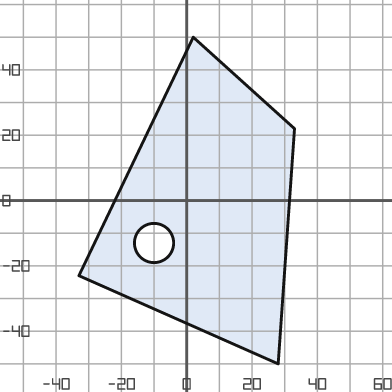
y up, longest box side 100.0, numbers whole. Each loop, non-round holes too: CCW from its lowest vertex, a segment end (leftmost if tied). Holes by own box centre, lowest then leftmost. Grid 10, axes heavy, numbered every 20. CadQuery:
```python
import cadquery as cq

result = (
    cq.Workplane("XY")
    .moveTo(28.0, -50.0)
    .lineTo(33.0, 22.0)
    .lineTo(2.0, 50.0)
    .lineTo(-33.0, -23.0)
    .close()
    .moveTo(-10.0, -13.0)
    .circle(6.0)
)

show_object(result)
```